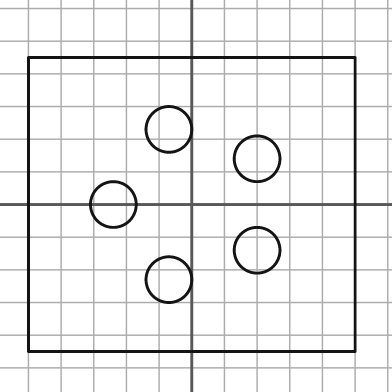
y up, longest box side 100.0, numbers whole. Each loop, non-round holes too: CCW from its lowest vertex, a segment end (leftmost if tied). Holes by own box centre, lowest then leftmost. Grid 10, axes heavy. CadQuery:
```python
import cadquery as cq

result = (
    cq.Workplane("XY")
    .moveTo(-50.0, -45.0)
    .lineTo(50.0, -45.0)
    .lineTo(50.0, 45.0)
    .lineTo(-50.0, 45.0)
    .close()
    .moveTo(-7.0, -23.0)
    .circle(7.0)
    .moveTo(20.0, -14.0)
    .circle(7.0)
    .moveTo(-24.0, 0.0)
    .circle(7.0)
    .moveTo(20.0, 14.0)
    .circle(7.0)
    .moveTo(-7.0, 23.0)
    .circle(7.0)
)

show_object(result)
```